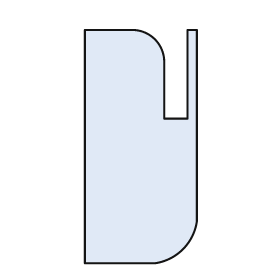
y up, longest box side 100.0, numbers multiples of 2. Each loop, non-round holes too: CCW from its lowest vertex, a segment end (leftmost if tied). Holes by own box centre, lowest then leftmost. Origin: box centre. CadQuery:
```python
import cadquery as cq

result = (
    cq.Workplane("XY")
    .moveTo(-24.0, -50.0)
    .lineTo(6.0, -50.0)
    .threePointArc((18.0, -44.0), (24.0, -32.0))
    .lineTo(24.0, 50.0)
    .lineTo(20.0, 50.0)
    .lineTo(20.0, 12.0)
    .lineTo(10.0, 12.0)
    .lineTo(10.0, 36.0)
    .threePointArc((6.0, 46.0), (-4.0, 50.0))
    .lineTo(-24.0, 50.0)
    .close()
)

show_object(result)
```